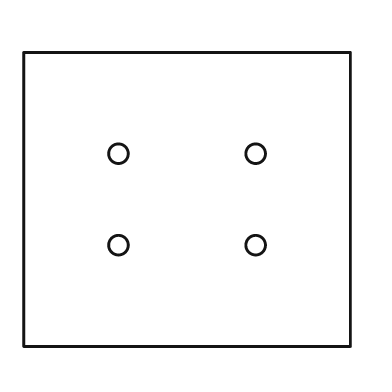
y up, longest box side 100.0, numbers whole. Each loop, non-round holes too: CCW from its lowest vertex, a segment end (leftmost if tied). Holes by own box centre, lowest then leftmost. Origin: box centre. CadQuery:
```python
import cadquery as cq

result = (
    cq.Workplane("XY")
    .moveTo(-50.0, -45.0)
    .lineTo(50.0, -45.0)
    .lineTo(50.0, 45.0)
    .lineTo(-50.0, 45.0)
    .close()
    .moveTo(-21.0, -14.0)
    .circle(3.0)
    .moveTo(21.0, -14.0)
    .circle(3.0)
    .moveTo(-21.0, 14.0)
    .circle(3.0)
    .moveTo(21.0, 14.0)
    .circle(3.0)
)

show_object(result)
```